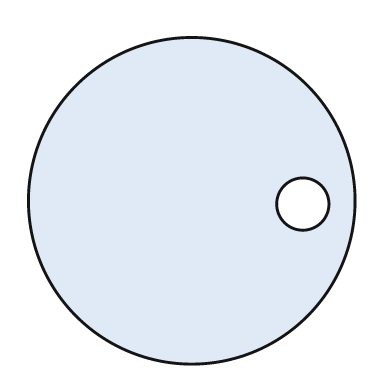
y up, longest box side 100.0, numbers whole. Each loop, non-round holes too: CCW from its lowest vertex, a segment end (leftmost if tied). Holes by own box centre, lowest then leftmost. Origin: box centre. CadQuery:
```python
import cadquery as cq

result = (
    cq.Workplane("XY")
    .moveTo(0.0, 0.0)
    .circle(50.0)
    .moveTo(34.0, -1.0)
    .circle(8.0)
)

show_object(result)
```